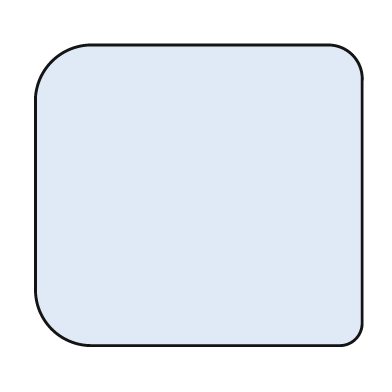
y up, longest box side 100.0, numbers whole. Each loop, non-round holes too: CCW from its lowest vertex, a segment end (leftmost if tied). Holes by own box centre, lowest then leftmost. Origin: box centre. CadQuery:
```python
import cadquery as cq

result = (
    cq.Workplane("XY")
    .moveTo(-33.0, -46.0)
    .lineTo(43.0, -46.0)
    .threePointArc((48.0, -44.0), (50.0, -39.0))
    .lineTo(50.0, 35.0)
    .threePointArc((47.0, 43.0), (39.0, 46.0))
    .lineTo(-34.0, 46.0)
    .threePointArc((-45.0, 41.0), (-50.0, 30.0))
    .lineTo(-50.0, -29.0)
    .threePointArc((-45.0, -41.0), (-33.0, -46.0))
    .close()
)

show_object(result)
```